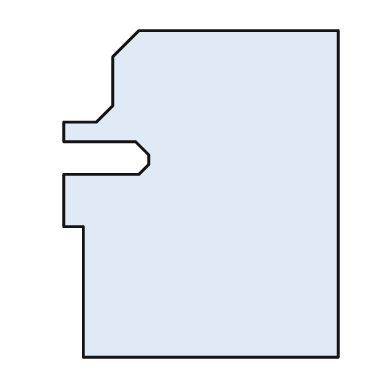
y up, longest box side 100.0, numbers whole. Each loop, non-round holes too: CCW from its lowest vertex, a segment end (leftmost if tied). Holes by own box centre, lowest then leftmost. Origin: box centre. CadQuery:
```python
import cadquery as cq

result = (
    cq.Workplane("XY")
    .moveTo(-36.0, -50.0)
    .lineTo(42.0, -50.0)
    .lineTo(42.0, 50.0)
    .lineTo(-19.0, 50.0)
    .lineTo(-27.0, 42.0)
    .lineTo(-27.0, 27.0)
    .lineTo(-32.0, 22.0)
    .lineTo(-42.0, 22.0)
    .lineTo(-42.0, 16.0)
    .lineTo(-20.0, 16.0)
    .lineTo(-16.0, 12.0)
    .lineTo(-16.0, 9.0)
    .lineTo(-19.0, 6.0)
    .lineTo(-42.0, 6.0)
    .lineTo(-42.0, -10.0)
    .lineTo(-36.0, -10.0)
    .close()
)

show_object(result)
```